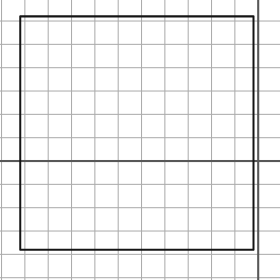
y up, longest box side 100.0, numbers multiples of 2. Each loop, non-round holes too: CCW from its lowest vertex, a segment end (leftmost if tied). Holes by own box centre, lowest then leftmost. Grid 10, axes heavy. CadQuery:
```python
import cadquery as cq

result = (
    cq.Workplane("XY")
    .moveTo(-102.0, -38.0)
    .lineTo(-2.0, -38.0)
    .lineTo(-2.0, 62.0)
    .lineTo(-102.0, 62.0)
    .close()
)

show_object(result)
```